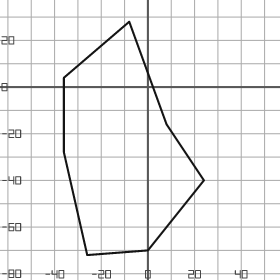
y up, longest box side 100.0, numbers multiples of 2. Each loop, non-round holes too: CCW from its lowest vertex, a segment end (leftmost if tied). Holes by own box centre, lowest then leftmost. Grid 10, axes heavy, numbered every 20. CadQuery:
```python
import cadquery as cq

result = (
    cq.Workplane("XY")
    .moveTo(-26.0, -72.0)
    .lineTo(0.0, -70.0)
    .lineTo(24.0, -40.0)
    .lineTo(8.0, -16.0)
    .lineTo(-8.0, 28.0)
    .lineTo(-36.0, 4.0)
    .lineTo(-36.0, -28.0)
    .close()
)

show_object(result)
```